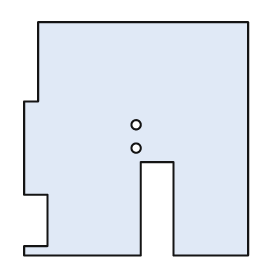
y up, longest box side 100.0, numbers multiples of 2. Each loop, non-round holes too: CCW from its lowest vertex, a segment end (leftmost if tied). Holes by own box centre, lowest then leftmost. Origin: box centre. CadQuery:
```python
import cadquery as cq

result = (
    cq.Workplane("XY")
    .moveTo(-48.0, -50.0)
    .lineTo(2.0, -50.0)
    .lineTo(2.0, -10.0)
    .lineTo(16.0, -10.0)
    .lineTo(16.0, -50.0)
    .lineTo(48.0, -50.0)
    .lineTo(48.0, 50.0)
    .lineTo(-42.0, 50.0)
    .lineTo(-42.0, 16.0)
    .lineTo(-48.0, 16.0)
    .lineTo(-48.0, -24.0)
    .lineTo(-38.0, -24.0)
    .lineTo(-38.0, -46.0)
    .lineTo(-48.0, -46.0)
    .close()
    .moveTo(0.0, -4.0)
    .circle(2.0)
    .moveTo(0.0, 6.0)
    .circle(2.0)
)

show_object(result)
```